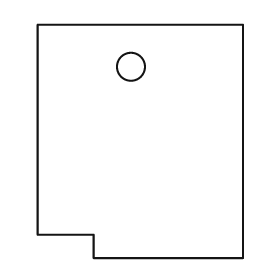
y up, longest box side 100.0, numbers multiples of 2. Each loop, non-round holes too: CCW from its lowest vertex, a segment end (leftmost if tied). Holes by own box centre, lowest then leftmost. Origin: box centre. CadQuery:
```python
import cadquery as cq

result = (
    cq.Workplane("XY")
    .moveTo(-20.0, -50.0)
    .lineTo(44.0, -50.0)
    .lineTo(44.0, 50.0)
    .lineTo(-44.0, 50.0)
    .lineTo(-44.0, -40.0)
    .lineTo(-20.0, -40.0)
    .close()
    .moveTo(-4.0, 32.0)
    .circle(6.0)
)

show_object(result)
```